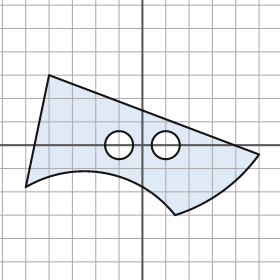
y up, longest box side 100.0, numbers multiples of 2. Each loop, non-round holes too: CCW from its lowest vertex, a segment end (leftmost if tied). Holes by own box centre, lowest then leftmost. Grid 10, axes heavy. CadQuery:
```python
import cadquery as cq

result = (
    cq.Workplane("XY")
    .moveTo(14.0, -30.0)
    .threePointArc((34.0, -20.0), (50.0, -4.0))
    .lineTo(-40.0, 30.0)
    .lineTo(-50.0, -18.0)
    .threePointArc((-16.0, -12.0), (14.0, -30.0))
    .close()
    .moveTo(-10.0, 0.0)
    .circle(6.0)
    .moveTo(10.0, 0.0)
    .circle(6.0)
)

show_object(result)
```